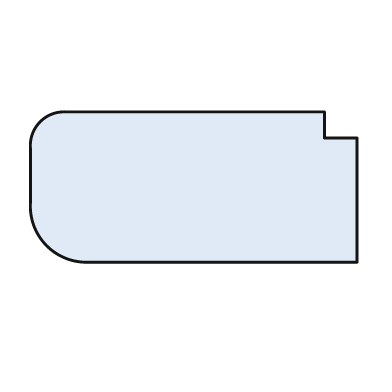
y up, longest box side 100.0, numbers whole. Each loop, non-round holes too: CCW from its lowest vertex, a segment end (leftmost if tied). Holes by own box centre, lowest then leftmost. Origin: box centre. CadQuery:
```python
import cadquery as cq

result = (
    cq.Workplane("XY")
    .moveTo(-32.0, -23.0)
    .lineTo(50.0, -23.0)
    .lineTo(50.0, 15.0)
    .lineTo(40.0, 15.0)
    .lineTo(40.0, 23.0)
    .lineTo(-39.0, 23.0)
    .threePointArc((-47.0, 20.0), (-50.0, 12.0))
    .lineTo(-50.0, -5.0)
    .threePointArc((-45.0, -18.0), (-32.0, -23.0))
    .close()
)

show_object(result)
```